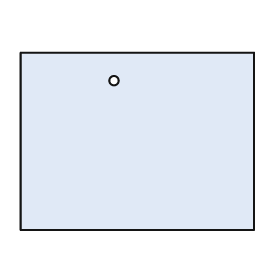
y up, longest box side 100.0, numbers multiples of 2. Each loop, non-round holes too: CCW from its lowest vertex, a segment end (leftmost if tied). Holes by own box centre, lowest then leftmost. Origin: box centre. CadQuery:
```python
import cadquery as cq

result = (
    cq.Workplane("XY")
    .moveTo(-50.0, -38.0)
    .lineTo(50.0, -38.0)
    .lineTo(50.0, 38.0)
    .lineTo(-50.0, 38.0)
    .close()
    .moveTo(-10.0, 26.0)
    .circle(2.0)
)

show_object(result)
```